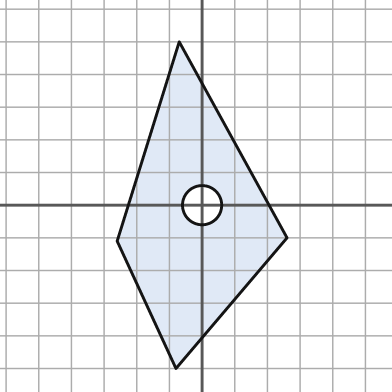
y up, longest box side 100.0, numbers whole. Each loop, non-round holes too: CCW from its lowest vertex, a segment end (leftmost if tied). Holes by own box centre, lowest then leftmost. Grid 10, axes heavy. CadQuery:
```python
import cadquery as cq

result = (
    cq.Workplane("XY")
    .moveTo(-8.0, -50.0)
    .lineTo(26.0, -10.0)
    .lineTo(-7.0, 50.0)
    .lineTo(-26.0, -11.0)
    .close()
    .moveTo(0.0, 0.0)
    .circle(6.0)
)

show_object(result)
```